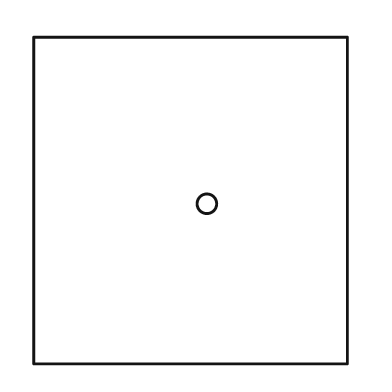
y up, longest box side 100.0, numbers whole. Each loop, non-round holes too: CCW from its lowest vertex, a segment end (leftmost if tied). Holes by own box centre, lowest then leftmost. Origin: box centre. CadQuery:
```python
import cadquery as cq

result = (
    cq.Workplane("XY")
    .moveTo(-48.0, -50.0)
    .lineTo(48.0, -50.0)
    .lineTo(48.0, 50.0)
    .lineTo(-48.0, 50.0)
    .close()
    .moveTo(5.0, -1.0)
    .circle(3.0)
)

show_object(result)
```